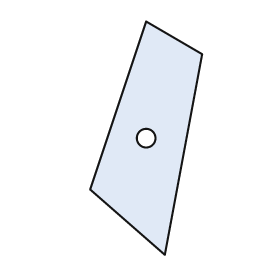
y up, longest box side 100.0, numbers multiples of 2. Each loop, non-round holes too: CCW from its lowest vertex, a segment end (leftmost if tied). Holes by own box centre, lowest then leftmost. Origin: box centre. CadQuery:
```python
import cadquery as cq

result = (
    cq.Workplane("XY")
    .moveTo(8.0, -50.0)
    .lineTo(24.0, 36.0)
    .lineTo(0.0, 50.0)
    .lineTo(-24.0, -22.0)
    .close()
    .moveTo(0.0, 0.0)
    .circle(4.0)
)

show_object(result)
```